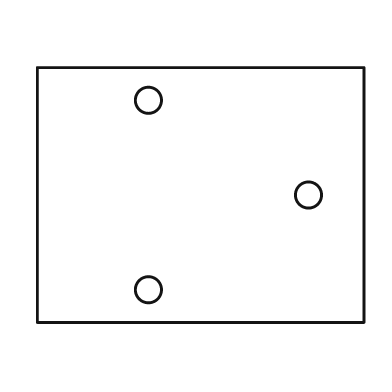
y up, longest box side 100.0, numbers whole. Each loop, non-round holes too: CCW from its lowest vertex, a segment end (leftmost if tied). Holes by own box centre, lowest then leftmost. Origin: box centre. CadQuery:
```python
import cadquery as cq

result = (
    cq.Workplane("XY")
    .moveTo(-50.0, -39.0)
    .lineTo(50.0, -39.0)
    .lineTo(50.0, 39.0)
    .lineTo(-50.0, 39.0)
    .close()
    .moveTo(-16.0, -29.0)
    .circle(4.0)
    .moveTo(33.0, 0.0)
    .circle(4.0)
    .moveTo(-16.0, 29.0)
    .circle(4.0)
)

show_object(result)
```